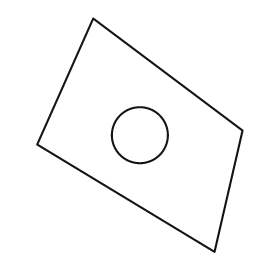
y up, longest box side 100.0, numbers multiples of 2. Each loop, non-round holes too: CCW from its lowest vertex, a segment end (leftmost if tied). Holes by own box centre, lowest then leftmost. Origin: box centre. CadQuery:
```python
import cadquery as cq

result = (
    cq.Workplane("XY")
    .moveTo(32.0, -50.0)
    .lineTo(44.0, 2.0)
    .lineTo(-20.0, 50.0)
    .lineTo(-44.0, -4.0)
    .close()
    .moveTo(0.0, 0.0)
    .circle(12.0)
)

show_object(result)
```